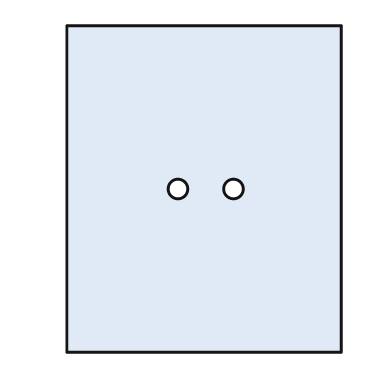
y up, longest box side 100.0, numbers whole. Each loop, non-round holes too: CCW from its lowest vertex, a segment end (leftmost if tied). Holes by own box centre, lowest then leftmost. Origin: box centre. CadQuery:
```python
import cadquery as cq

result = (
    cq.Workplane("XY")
    .moveTo(-42.0, -50.0)
    .lineTo(42.0, -50.0)
    .lineTo(42.0, 50.0)
    .lineTo(-42.0, 50.0)
    .close()
    .moveTo(-8.0, 0.0)
    .circle(3.0)
    .moveTo(9.0, 0.0)
    .circle(3.0)
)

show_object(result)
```